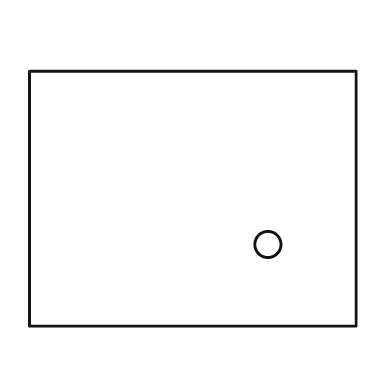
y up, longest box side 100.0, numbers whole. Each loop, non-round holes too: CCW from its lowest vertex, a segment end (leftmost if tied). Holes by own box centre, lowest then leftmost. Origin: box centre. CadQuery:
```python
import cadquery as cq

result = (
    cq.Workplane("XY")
    .moveTo(-50.0, -39.0)
    .lineTo(50.0, -39.0)
    .lineTo(50.0, 39.0)
    .lineTo(-50.0, 39.0)
    .close()
    .moveTo(23.0, -14.0)
    .circle(4.0)
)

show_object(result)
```